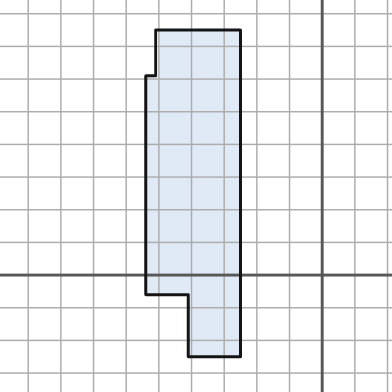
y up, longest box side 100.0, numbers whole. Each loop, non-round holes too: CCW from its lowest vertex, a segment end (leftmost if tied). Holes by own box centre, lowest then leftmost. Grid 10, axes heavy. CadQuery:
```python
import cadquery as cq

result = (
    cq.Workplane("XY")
    .moveTo(-41.0, -25.0)
    .lineTo(-25.0, -25.0)
    .lineTo(-25.0, 75.0)
    .lineTo(-51.0, 75.0)
    .lineTo(-51.0, 61.0)
    .lineTo(-54.0, 61.0)
    .lineTo(-54.0, -6.0)
    .lineTo(-41.0, -6.0)
    .close()
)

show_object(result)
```